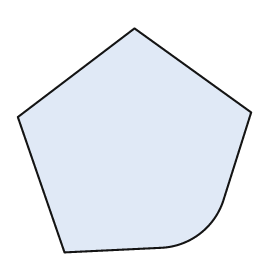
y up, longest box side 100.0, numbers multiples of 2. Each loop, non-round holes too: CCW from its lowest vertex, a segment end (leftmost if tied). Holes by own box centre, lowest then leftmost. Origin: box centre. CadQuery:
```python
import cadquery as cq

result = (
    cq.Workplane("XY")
    .moveTo(-30.0, -48.0)
    .lineTo(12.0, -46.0)
    .threePointArc((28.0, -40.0), (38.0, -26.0))
    .lineTo(50.0, 12.0)
    .lineTo(0.0, 48.0)
    .lineTo(-50.0, 10.0)
    .close()
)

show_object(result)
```